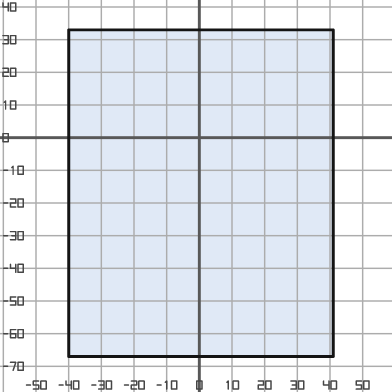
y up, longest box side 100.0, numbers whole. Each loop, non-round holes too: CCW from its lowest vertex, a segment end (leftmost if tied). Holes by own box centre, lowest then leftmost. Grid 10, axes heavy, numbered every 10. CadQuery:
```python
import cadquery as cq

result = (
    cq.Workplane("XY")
    .moveTo(-40.0, -67.0)
    .lineTo(41.0, -67.0)
    .lineTo(41.0, 33.0)
    .lineTo(-40.0, 33.0)
    .close()
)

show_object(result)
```